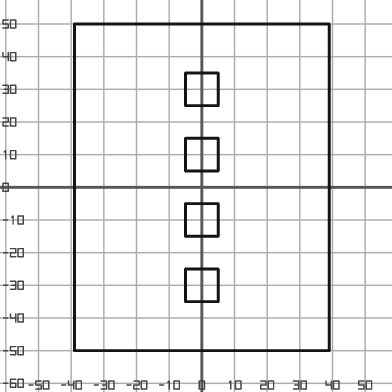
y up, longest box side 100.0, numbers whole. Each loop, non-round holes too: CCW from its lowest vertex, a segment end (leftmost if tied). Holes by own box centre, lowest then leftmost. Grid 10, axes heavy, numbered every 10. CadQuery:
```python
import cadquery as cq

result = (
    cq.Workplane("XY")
    .moveTo(-39.0, -50.0)
    .lineTo(39.0, -50.0)
    .lineTo(39.0, 50.0)
    .lineTo(-39.0, 50.0)
    .close()
    .moveTo(-5.0, -35.0)
    .lineTo(5.0, -35.0)
    .lineTo(5.0, -25.0)
    .lineTo(-5.0, -25.0)
    .close()
    .moveTo(-5.0, -15.0)
    .lineTo(5.0, -15.0)
    .lineTo(5.0, -5.0)
    .lineTo(-5.0, -5.0)
    .close()
    .moveTo(-5.0, 5.0)
    .lineTo(5.0, 5.0)
    .lineTo(5.0, 15.0)
    .lineTo(-5.0, 15.0)
    .close()
    .moveTo(-5.0, 25.0)
    .lineTo(5.0, 25.0)
    .lineTo(5.0, 35.0)
    .lineTo(-5.0, 35.0)
    .close()
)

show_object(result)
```